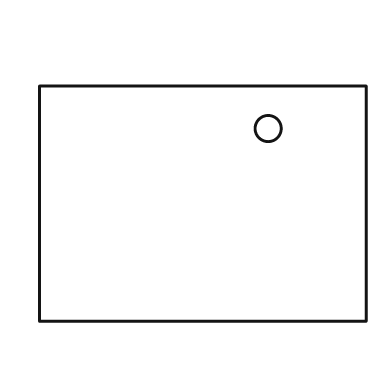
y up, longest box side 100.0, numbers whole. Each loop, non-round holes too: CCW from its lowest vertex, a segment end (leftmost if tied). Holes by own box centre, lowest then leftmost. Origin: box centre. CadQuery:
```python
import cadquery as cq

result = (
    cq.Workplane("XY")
    .moveTo(-50.0, -36.0)
    .lineTo(50.0, -36.0)
    .lineTo(50.0, 36.0)
    .lineTo(-50.0, 36.0)
    .close()
    .moveTo(20.0, 23.0)
    .circle(4.0)
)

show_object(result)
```